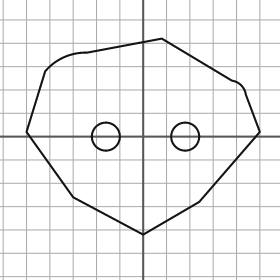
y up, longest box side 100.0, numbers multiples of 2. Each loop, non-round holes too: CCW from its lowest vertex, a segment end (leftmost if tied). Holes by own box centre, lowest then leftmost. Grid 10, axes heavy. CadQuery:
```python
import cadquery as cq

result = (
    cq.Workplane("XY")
    .moveTo(0.0, -42.0)
    .lineTo(24.0, -28.0)
    .lineTo(50.0, 2.0)
    .lineTo(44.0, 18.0)
    .threePointArc((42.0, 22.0), (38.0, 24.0))
    .lineTo(8.0, 42.0)
    .lineTo(-24.0, 36.0)
    .threePointArc((-34.0, 34.0), (-42.0, 28.0))
    .lineTo(-50.0, 2.0)
    .lineTo(-30.0, -26.0)
    .close()
    .moveTo(-16.0, 0.0)
    .circle(6.0)
    .moveTo(18.0, 0.0)
    .circle(6.0)
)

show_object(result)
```